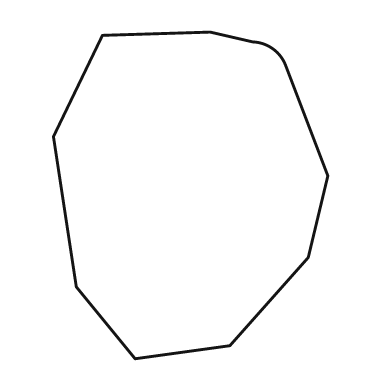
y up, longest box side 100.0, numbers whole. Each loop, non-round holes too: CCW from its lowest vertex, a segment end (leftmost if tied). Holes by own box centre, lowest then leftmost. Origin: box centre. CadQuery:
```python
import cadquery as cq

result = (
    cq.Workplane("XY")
    .moveTo(-17.0, -50.0)
    .lineTo(12.0, -46.0)
    .lineTo(36.0, -19.0)
    .lineTo(42.0, 6.0)
    .lineTo(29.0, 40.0)
    .threePointArc((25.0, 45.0), (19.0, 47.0))
    .lineTo(6.0, 50.0)
    .lineTo(-27.0, 49.0)
    .lineTo(-42.0, 18.0)
    .lineTo(-35.0, -28.0)
    .close()
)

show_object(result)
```